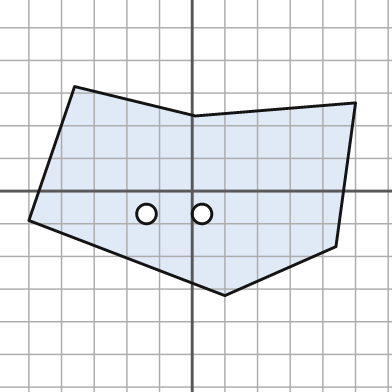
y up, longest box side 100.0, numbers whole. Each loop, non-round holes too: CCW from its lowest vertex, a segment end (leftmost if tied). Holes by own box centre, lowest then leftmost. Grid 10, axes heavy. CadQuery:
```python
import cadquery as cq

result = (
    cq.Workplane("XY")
    .moveTo(10.0, -32.0)
    .lineTo(44.0, -17.0)
    .lineTo(50.0, 27.0)
    .lineTo(1.0, 23.0)
    .lineTo(-36.0, 32.0)
    .lineTo(-50.0, -9.0)
    .close()
    .moveTo(-14.0, -7.0)
    .circle(3.0)
    .moveTo(3.0, -7.0)
    .circle(3.0)
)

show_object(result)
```